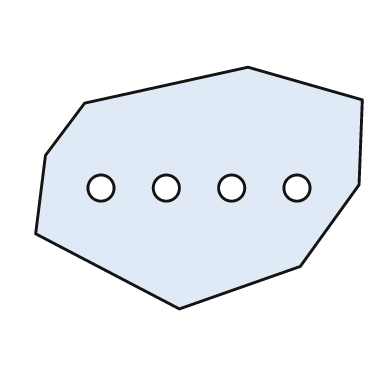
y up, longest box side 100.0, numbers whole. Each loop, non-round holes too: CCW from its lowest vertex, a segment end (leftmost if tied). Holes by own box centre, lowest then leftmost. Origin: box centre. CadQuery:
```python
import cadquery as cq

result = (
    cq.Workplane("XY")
    .moveTo(-6.0, -37.0)
    .lineTo(31.0, -24.0)
    .lineTo(49.0, 1.0)
    .lineTo(50.0, 27.0)
    .lineTo(15.0, 37.0)
    .lineTo(-35.0, 26.0)
    .lineTo(-47.0, 10.0)
    .lineTo(-50.0, -14.0)
    .close()
    .moveTo(-30.0, 0.0)
    .circle(4.0)
    .moveTo(-10.0, 0.0)
    .circle(4.0)
    .moveTo(10.0, 0.0)
    .circle(4.0)
    .moveTo(30.0, 0.0)
    .circle(4.0)
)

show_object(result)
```